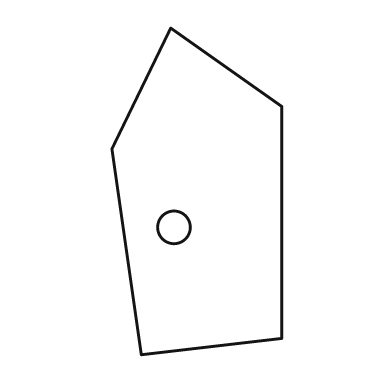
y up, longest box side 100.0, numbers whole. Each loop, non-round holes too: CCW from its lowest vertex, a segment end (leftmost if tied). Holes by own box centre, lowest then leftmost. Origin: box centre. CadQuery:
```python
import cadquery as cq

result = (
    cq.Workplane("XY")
    .moveTo(-17.0, -50.0)
    .lineTo(26.0, -45.0)
    .lineTo(26.0, 26.0)
    .lineTo(-8.0, 50.0)
    .lineTo(-26.0, 13.0)
    .close()
    .moveTo(-7.0, -11.0)
    .circle(5.0)
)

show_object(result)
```